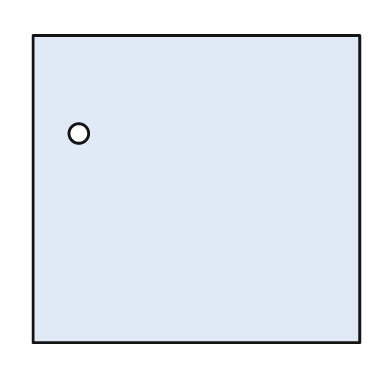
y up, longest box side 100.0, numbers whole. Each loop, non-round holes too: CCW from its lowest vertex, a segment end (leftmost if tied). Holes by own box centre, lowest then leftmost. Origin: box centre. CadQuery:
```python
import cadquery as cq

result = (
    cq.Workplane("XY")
    .moveTo(-50.0, -47.0)
    .lineTo(50.0, -47.0)
    .lineTo(50.0, 47.0)
    .lineTo(-50.0, 47.0)
    .close()
    .moveTo(-36.0, 17.0)
    .circle(3.0)
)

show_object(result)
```